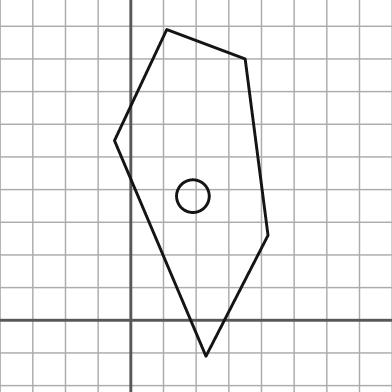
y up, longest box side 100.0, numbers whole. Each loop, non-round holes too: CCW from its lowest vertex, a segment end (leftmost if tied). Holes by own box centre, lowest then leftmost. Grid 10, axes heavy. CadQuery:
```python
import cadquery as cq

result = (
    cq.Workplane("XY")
    .moveTo(23.0, -11.0)
    .lineTo(42.0, 26.0)
    .lineTo(35.0, 80.0)
    .lineTo(11.0, 89.0)
    .lineTo(-5.0, 55.0)
    .close()
    .moveTo(19.0, 38.0)
    .circle(5.0)
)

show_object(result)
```